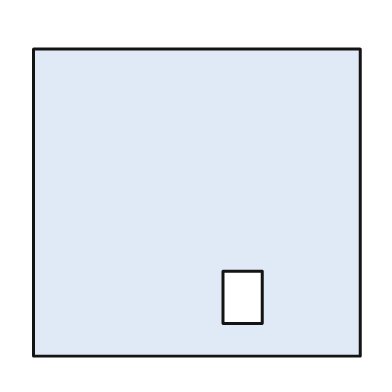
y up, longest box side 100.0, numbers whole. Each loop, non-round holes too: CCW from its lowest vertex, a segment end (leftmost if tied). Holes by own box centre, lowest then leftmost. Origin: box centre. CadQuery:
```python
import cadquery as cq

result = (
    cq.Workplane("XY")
    .moveTo(-50.0, -47.0)
    .lineTo(50.0, -47.0)
    .lineTo(50.0, 47.0)
    .lineTo(-50.0, 47.0)
    .close()
    .moveTo(8.0, -37.0)
    .lineTo(20.0, -37.0)
    .lineTo(20.0, -21.0)
    .lineTo(8.0, -21.0)
    .close()
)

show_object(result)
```